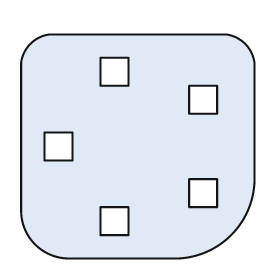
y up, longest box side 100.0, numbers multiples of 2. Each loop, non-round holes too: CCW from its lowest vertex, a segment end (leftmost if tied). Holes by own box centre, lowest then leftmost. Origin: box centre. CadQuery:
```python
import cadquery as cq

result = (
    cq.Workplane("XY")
    .moveTo(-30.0, -48.0)
    .lineTo(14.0, -48.0)
    .threePointArc((40.0, -38.0), (50.0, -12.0))
    .lineTo(50.0, 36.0)
    .threePointArc((46.0, 44.0), (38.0, 48.0))
    .lineTo(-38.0, 48.0)
    .threePointArc((-46.0, 44.0), (-50.0, 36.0))
    .lineTo(-50.0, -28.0)
    .threePointArc((-44.0, -42.0), (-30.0, -48.0))
    .close()
    .moveTo(-16.0, -38.0)
    .lineTo(-4.0, -38.0)
    .lineTo(-4.0, -26.0)
    .lineTo(-16.0, -26.0)
    .close()
    .moveTo(22.0, -26.0)
    .lineTo(34.0, -26.0)
    .lineTo(34.0, -14.0)
    .lineTo(22.0, -14.0)
    .close()
    .moveTo(-40.0, -6.0)
    .lineTo(-28.0, -6.0)
    .lineTo(-28.0, 6.0)
    .lineTo(-40.0, 6.0)
    .close()
    .moveTo(22.0, 14.0)
    .lineTo(34.0, 14.0)
    .lineTo(34.0, 26.0)
    .lineTo(22.0, 26.0)
    .close()
    .moveTo(-16.0, 26.0)
    .lineTo(-4.0, 26.0)
    .lineTo(-4.0, 38.0)
    .lineTo(-16.0, 38.0)
    .close()
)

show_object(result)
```